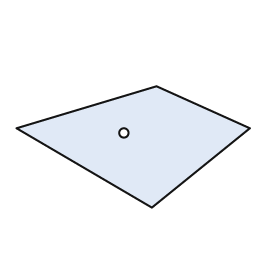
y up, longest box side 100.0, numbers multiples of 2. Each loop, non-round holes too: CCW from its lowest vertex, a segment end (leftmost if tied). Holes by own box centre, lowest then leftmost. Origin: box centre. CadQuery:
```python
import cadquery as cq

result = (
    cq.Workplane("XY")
    .moveTo(8.0, -26.0)
    .lineTo(50.0, 8.0)
    .lineTo(10.0, 26.0)
    .lineTo(-50.0, 8.0)
    .close()
    .moveTo(-4.0, 6.0)
    .circle(2.0)
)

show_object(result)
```